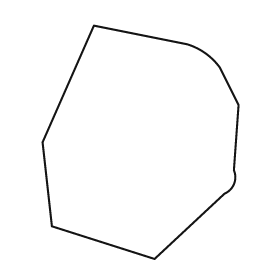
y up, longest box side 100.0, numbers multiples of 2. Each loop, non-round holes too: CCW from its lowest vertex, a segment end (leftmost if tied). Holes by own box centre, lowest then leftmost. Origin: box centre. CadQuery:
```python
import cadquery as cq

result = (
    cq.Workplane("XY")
    .moveTo(6.0, -50.0)
    .lineTo(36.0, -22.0)
    .threePointArc((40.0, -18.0), (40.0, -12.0))
    .lineTo(42.0, 16.0)
    .lineTo(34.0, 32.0)
    .threePointArc((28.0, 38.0), (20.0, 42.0))
    .lineTo(-20.0, 50.0)
    .lineTo(-42.0, 0.0)
    .lineTo(-38.0, -36.0)
    .close()
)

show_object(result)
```